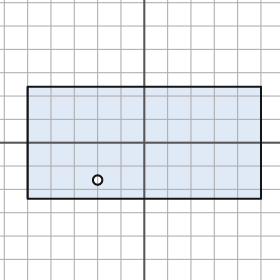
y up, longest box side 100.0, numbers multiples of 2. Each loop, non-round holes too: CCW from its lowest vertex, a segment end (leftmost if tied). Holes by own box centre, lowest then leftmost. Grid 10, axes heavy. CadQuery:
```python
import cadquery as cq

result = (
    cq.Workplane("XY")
    .moveTo(-50.0, -24.0)
    .lineTo(50.0, -24.0)
    .lineTo(50.0, 24.0)
    .lineTo(-50.0, 24.0)
    .close()
    .moveTo(-20.0, -16.0)
    .circle(2.0)
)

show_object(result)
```